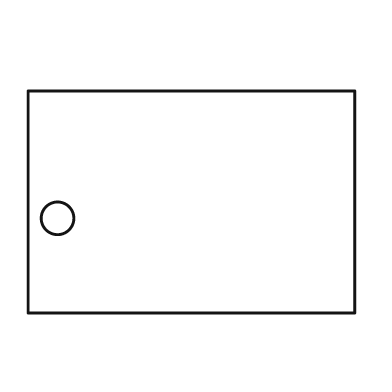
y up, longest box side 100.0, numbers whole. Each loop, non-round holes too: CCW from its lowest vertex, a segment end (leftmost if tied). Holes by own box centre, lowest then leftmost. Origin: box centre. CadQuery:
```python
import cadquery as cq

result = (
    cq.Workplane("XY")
    .moveTo(-50.0, -34.0)
    .lineTo(50.0, -34.0)
    .lineTo(50.0, 34.0)
    .lineTo(-50.0, 34.0)
    .close()
    .moveTo(-41.0, -5.0)
    .circle(5.0)
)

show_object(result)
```